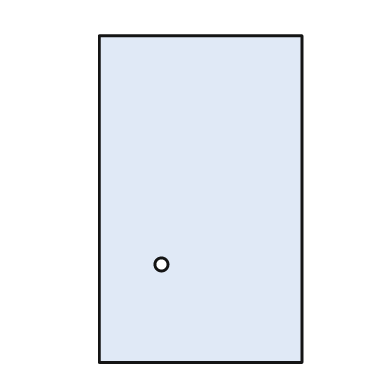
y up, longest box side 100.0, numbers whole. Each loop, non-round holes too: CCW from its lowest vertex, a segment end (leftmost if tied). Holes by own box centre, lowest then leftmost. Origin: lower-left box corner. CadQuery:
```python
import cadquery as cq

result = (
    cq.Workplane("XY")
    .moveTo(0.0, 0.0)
    .lineTo(62.0, 0.0)
    .lineTo(62.0, 100.0)
    .lineTo(0.0, 100.0)
    .close()
    .moveTo(19.0, 30.0)
    .circle(2.0)
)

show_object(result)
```